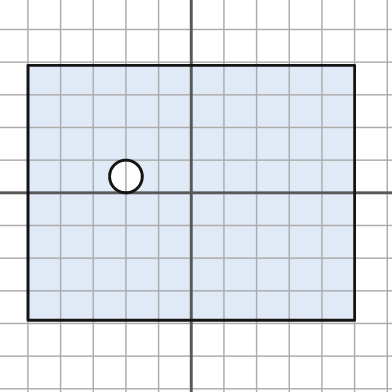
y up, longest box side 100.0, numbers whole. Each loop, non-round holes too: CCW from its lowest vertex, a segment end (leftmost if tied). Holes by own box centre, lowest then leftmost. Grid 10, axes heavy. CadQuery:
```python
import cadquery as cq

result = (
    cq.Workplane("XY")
    .moveTo(-50.0, -39.0)
    .lineTo(50.0, -39.0)
    .lineTo(50.0, 39.0)
    .lineTo(-50.0, 39.0)
    .close()
    .moveTo(-20.0, 5.0)
    .circle(5.0)
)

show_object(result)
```